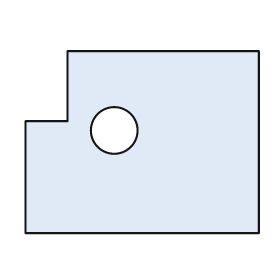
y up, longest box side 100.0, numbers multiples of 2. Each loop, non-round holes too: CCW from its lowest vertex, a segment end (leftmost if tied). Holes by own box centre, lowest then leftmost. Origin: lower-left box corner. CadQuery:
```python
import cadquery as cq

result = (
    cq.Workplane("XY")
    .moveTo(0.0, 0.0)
    .lineTo(100.0, 0.0)
    .lineTo(100.0, 78.0)
    .lineTo(18.0, 78.0)
    .lineTo(18.0, 48.0)
    .lineTo(0.0, 48.0)
    .close()
    .moveTo(38.0, 44.0)
    .circle(10.0)
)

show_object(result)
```